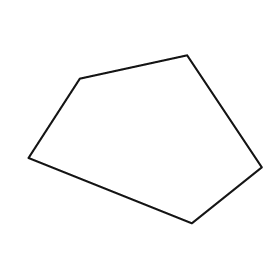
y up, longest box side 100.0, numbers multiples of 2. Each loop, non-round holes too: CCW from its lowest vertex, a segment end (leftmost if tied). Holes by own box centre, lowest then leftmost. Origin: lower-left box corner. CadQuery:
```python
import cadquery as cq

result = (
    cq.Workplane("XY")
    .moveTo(70.0, 0.0)
    .lineTo(100.0, 24.0)
    .lineTo(68.0, 72.0)
    .lineTo(22.0, 62.0)
    .lineTo(0.0, 28.0)
    .close()
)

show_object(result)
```